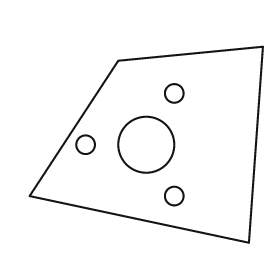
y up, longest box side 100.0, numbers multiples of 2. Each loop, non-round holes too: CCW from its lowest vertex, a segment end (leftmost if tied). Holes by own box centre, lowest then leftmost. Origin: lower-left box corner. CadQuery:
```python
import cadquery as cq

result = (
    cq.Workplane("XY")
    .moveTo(94.0, 0.0)
    .lineTo(100.0, 84.0)
    .lineTo(38.0, 78.0)
    .lineTo(0.0, 20.0)
    .close()
    .moveTo(62.0, 20.0)
    .circle(4.0)
    .moveTo(24.0, 42.0)
    .circle(4.0)
    .moveTo(50.0, 42.0)
    .circle(12.0)
    .moveTo(62.0, 64.0)
    .circle(4.0)
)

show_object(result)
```